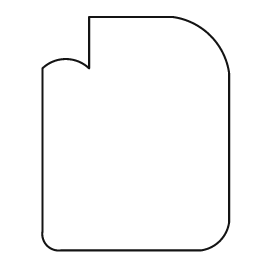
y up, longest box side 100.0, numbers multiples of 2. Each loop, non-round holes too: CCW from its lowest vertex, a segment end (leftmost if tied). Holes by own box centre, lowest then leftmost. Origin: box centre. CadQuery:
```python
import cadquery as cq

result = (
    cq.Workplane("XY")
    .moveTo(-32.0, -50.0)
    .lineTo(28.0, -50.0)
    .threePointArc((36.0, -46.0), (40.0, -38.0))
    .lineTo(40.0, 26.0)
    .threePointArc((32.0, 42.0), (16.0, 50.0))
    .lineTo(-20.0, 50.0)
    .lineTo(-20.0, 28.0)
    .threePointArc((-30.0, 32.0), (-40.0, 28.0))
    .lineTo(-40.0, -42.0)
    .threePointArc((-38.0, -48.0), (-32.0, -50.0))
    .close()
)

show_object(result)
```